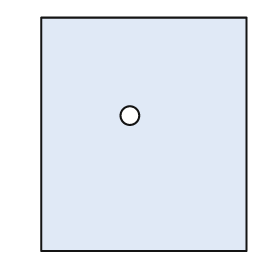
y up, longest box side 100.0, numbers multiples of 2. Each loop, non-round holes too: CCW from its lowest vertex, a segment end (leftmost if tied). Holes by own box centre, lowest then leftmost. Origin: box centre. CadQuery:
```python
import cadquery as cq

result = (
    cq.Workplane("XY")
    .moveTo(-44.0, -50.0)
    .lineTo(44.0, -50.0)
    .lineTo(44.0, 50.0)
    .lineTo(-44.0, 50.0)
    .close()
    .moveTo(-6.0, 8.0)
    .circle(4.0)
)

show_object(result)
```